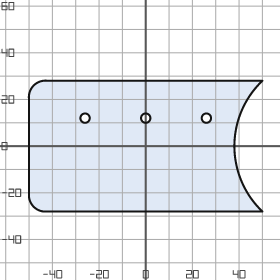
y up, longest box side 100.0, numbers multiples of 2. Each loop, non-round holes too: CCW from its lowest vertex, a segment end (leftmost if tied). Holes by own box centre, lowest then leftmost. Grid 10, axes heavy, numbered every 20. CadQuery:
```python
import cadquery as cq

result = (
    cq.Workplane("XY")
    .moveTo(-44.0, -28.0)
    .lineTo(50.0, -28.0)
    .threePointArc((38.0, 0.0), (50.0, 28.0))
    .lineTo(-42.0, 28.0)
    .threePointArc((-48.0, 26.0), (-50.0, 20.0))
    .lineTo(-50.0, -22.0)
    .threePointArc((-48.0, -26.0), (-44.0, -28.0))
    .close()
    .moveTo(-26.0, 12.0)
    .circle(2.0)
    .moveTo(0.0, 12.0)
    .circle(2.0)
    .moveTo(26.0, 12.0)
    .circle(2.0)
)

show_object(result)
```